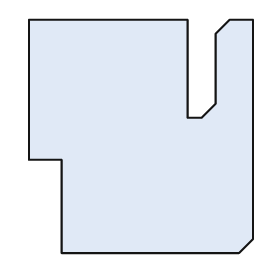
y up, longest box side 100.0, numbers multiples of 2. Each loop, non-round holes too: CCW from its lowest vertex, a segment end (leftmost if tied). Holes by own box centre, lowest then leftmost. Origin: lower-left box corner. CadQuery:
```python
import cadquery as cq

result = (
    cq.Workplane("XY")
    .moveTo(14.0, 0.0)
    .lineTo(90.0, 0.0)
    .lineTo(96.0, 6.0)
    .lineTo(96.0, 100.0)
    .lineTo(86.0, 100.0)
    .lineTo(80.0, 94.0)
    .lineTo(80.0, 64.0)
    .lineTo(74.0, 58.0)
    .lineTo(68.0, 58.0)
    .lineTo(68.0, 100.0)
    .lineTo(0.0, 100.0)
    .lineTo(0.0, 40.0)
    .lineTo(14.0, 40.0)
    .close()
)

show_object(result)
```